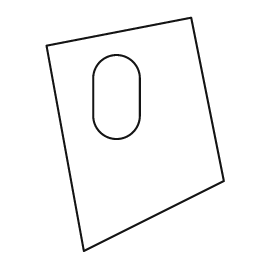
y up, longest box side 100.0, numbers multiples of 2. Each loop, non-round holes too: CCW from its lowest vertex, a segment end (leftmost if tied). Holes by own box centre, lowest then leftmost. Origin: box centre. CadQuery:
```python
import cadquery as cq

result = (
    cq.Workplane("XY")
    .moveTo(-22.0, -50.0)
    .lineTo(38.0, -20.0)
    .lineTo(24.0, 50.0)
    .lineTo(-38.0, 38.0)
    .close()
    .moveTo(-18.0, 8.0)
    .threePointArc((-8.0, -2.0), (2.0, 8.0))
    .lineTo(2.0, 24.0)
    .threePointArc((-8.0, 34.0), (-18.0, 24.0))
    .close()
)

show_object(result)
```